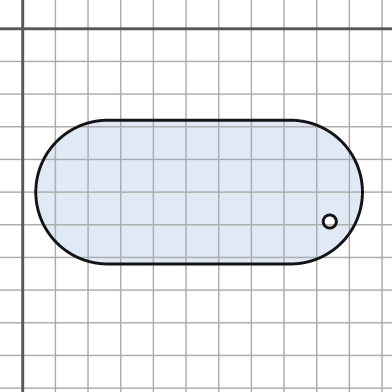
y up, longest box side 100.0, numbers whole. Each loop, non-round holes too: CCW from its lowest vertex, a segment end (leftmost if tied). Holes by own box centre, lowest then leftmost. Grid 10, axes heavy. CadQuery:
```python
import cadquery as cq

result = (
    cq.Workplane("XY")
    .moveTo(26.0, -72.0)
    .lineTo(82.0, -72.0)
    .threePointArc((104.0, -50.0), (82.0, -28.0))
    .lineTo(26.0, -28.0)
    .threePointArc((4.0, -50.0), (26.0, -72.0))
    .close()
    .moveTo(94.0, -59.0)
    .circle(2.0)
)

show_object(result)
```